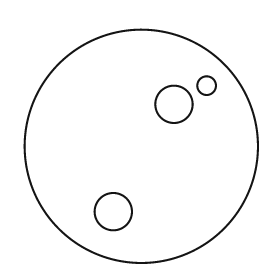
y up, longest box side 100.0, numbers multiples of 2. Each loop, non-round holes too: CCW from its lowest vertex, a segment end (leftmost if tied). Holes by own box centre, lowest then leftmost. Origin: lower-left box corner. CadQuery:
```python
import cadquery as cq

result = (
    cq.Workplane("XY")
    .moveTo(50.0, 50.0)
    .circle(50.0)
    .moveTo(38.0, 22.0)
    .circle(8.0)
    .moveTo(64.0, 68.0)
    .circle(8.0)
    .moveTo(78.0, 76.0)
    .circle(4.0)
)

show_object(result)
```